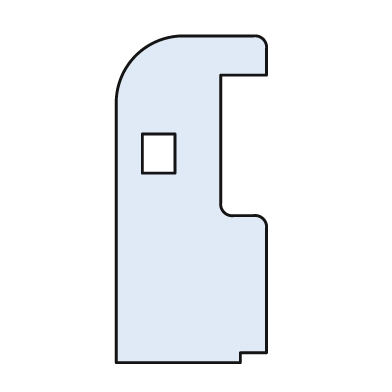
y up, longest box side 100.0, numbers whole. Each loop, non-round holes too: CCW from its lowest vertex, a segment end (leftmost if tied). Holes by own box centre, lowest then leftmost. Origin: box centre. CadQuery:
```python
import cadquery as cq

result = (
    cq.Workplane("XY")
    .moveTo(-23.0, -50.0)
    .lineTo(15.0, -50.0)
    .lineTo(15.0, -47.0)
    .lineTo(23.0, -47.0)
    .lineTo(23.0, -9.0)
    .threePointArc((22.0, -6.0), (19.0, -5.0))
    .lineTo(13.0, -5.0)
    .threePointArc((10.0, -4.0), (9.0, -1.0))
    .lineTo(9.0, 38.0)
    .lineTo(23.0, 38.0)
    .lineTo(23.0, 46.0)
    .threePointArc((22.0, 49.0), (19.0, 50.0))
    .lineTo(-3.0, 50.0)
    .threePointArc((-17.0, 44.0), (-23.0, 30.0))
    .close()
    .moveTo(-15.0, 8.0)
    .lineTo(-5.0, 8.0)
    .lineTo(-5.0, 20.0)
    .lineTo(-15.0, 20.0)
    .close()
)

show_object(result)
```